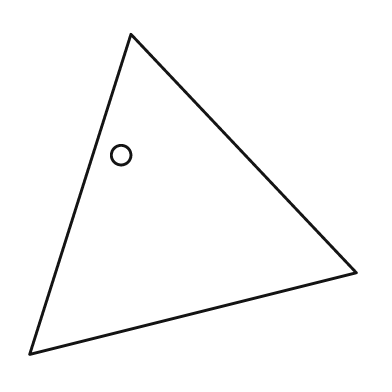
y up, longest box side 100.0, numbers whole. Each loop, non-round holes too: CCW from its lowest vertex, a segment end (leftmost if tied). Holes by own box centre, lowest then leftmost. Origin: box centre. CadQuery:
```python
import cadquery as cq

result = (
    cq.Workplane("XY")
    .moveTo(-50.0, -49.0)
    .lineTo(50.0, -24.0)
    .lineTo(-19.0, 49.0)
    .close()
    .moveTo(-22.0, 12.0)
    .circle(3.0)
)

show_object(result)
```